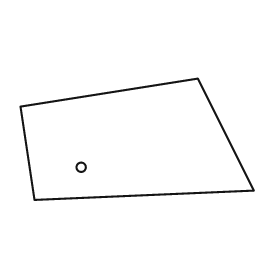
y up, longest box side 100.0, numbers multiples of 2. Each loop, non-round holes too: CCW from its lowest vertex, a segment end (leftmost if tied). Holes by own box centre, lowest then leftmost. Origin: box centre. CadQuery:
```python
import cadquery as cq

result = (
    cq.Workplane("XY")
    .moveTo(-44.0, -26.0)
    .lineTo(50.0, -22.0)
    .lineTo(26.0, 26.0)
    .lineTo(-50.0, 14.0)
    .close()
    .moveTo(-24.0, -12.0)
    .circle(2.0)
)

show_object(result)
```